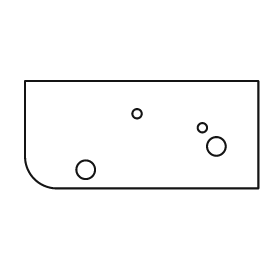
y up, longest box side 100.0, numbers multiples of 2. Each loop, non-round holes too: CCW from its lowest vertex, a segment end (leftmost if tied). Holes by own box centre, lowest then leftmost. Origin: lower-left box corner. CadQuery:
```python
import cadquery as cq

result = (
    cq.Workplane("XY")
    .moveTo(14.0, 0.0)
    .lineTo(100.0, 0.0)
    .lineTo(100.0, 46.0)
    .lineTo(0.0, 46.0)
    .lineTo(0.0, 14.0)
    .threePointArc((4.0, 4.0), (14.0, 0.0))
    .close()
    .moveTo(26.0, 8.0)
    .circle(4.0)
    .moveTo(82.0, 18.0)
    .circle(4.0)
    .moveTo(76.0, 26.0)
    .circle(2.0)
    .moveTo(48.0, 32.0)
    .circle(2.0)
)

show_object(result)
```